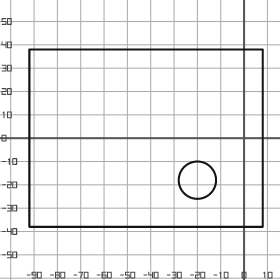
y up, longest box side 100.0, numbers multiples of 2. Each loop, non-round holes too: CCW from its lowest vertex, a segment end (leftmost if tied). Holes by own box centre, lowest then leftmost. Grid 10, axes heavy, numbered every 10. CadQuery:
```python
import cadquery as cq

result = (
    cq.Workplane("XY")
    .moveTo(-92.0, -38.0)
    .lineTo(8.0, -38.0)
    .lineTo(8.0, 38.0)
    .lineTo(-92.0, 38.0)
    .close()
    .moveTo(-20.0, -18.0)
    .circle(8.0)
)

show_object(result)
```